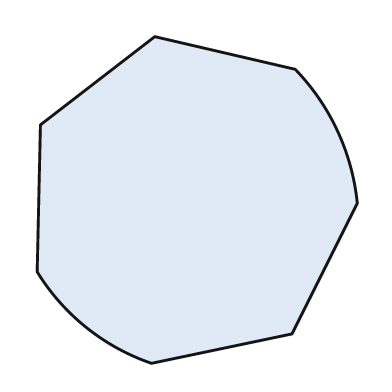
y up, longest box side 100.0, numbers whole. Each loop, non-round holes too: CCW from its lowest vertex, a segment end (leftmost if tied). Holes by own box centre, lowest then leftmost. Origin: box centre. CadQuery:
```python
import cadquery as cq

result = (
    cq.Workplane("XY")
    .moveTo(-14.0, -50.0)
    .lineTo(29.0, -41.0)
    .lineTo(49.0, -1.0)
    .threePointArc((43.0, 21.0), (30.0, 40.0))
    .lineTo(-13.0, 50.0)
    .lineTo(-48.0, 23.0)
    .lineTo(-49.0, -22.0)
    .threePointArc((-34.0, -39.0), (-14.0, -50.0))
    .close()
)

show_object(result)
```